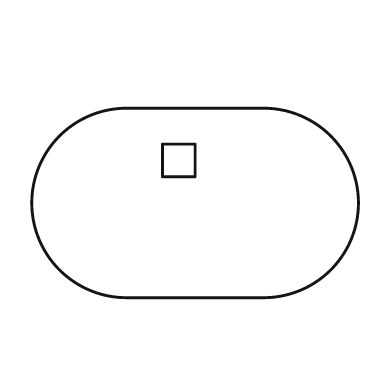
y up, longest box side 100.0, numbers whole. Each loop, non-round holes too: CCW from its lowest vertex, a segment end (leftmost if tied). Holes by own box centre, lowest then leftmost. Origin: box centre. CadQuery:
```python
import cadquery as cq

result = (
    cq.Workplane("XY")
    .moveTo(-21.0, -29.0)
    .lineTo(21.0, -29.0)
    .threePointArc((50.0, 0.0), (21.0, 29.0))
    .lineTo(-21.0, 29.0)
    .threePointArc((-50.0, 0.0), (-21.0, -29.0))
    .close()
    .moveTo(-10.0, 8.0)
    .lineTo(0.0, 8.0)
    .lineTo(0.0, 18.0)
    .lineTo(-10.0, 18.0)
    .close()
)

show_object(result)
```